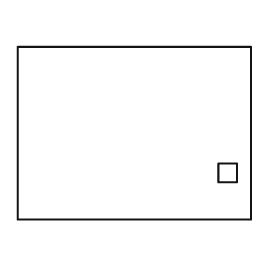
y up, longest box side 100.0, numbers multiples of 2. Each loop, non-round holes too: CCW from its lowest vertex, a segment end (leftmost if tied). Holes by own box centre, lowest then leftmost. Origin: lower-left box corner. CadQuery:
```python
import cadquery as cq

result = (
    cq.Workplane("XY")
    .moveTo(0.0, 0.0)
    .lineTo(100.0, 0.0)
    .lineTo(100.0, 74.0)
    .lineTo(0.0, 74.0)
    .close()
    .moveTo(86.0, 16.0)
    .lineTo(94.0, 16.0)
    .lineTo(94.0, 24.0)
    .lineTo(86.0, 24.0)
    .close()
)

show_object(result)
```